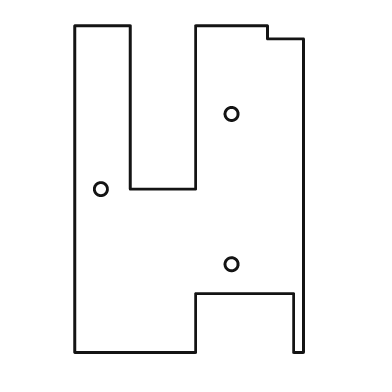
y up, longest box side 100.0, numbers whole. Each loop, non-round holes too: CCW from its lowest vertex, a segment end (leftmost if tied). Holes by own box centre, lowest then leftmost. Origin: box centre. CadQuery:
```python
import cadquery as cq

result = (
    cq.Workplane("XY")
    .moveTo(-35.0, -50.0)
    .lineTo(2.0, -50.0)
    .lineTo(2.0, -32.0)
    .lineTo(32.0, -32.0)
    .lineTo(32.0, -50.0)
    .lineTo(35.0, -50.0)
    .lineTo(35.0, 46.0)
    .lineTo(24.0, 46.0)
    .lineTo(24.0, 50.0)
    .lineTo(2.0, 50.0)
    .lineTo(2.0, 0.0)
    .lineTo(-18.0, 0.0)
    .lineTo(-18.0, 50.0)
    .lineTo(-35.0, 50.0)
    .close()
    .moveTo(13.0, -23.0)
    .circle(2.0)
    .moveTo(-27.0, 0.0)
    .circle(2.0)
    .moveTo(13.0, 23.0)
    .circle(2.0)
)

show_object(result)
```